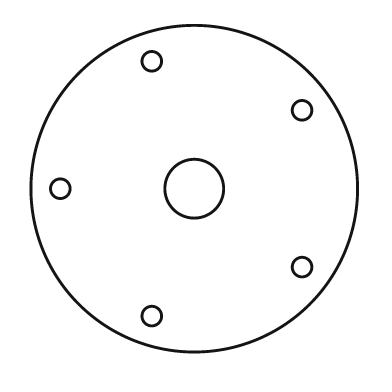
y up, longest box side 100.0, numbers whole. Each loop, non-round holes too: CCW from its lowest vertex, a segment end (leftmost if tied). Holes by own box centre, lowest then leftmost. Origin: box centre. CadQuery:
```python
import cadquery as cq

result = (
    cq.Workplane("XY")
    .moveTo(0.0, 0.0)
    .circle(50.0)
    .moveTo(-13.0, -39.0)
    .circle(3.0)
    .moveTo(33.0, -24.0)
    .circle(3.0)
    .moveTo(-41.0, 0.0)
    .circle(3.0)
    .moveTo(0.0, 0.0)
    .circle(9.0)
    .moveTo(33.0, 24.0)
    .circle(3.0)
    .moveTo(-13.0, 39.0)
    .circle(3.0)
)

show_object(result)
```